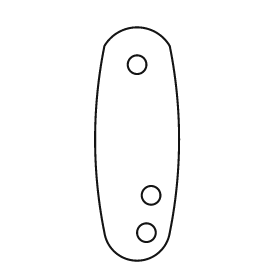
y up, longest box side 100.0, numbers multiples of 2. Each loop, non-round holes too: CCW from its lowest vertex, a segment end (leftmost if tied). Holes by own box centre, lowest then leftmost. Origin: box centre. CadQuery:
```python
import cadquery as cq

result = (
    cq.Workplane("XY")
    .moveTo(-14.0, -38.0)
    .threePointArc((0.0, -50.0), (14.0, -38.0))
    .threePointArc((18.0, 2.0), (14.0, 42.0))
    .threePointArc((0.0, 50.0), (-14.0, 42.0))
    .threePointArc((-18.0, 2.0), (-14.0, -38.0))
    .close()
    .moveTo(4.0, -38.0)
    .circle(4.0)
    .moveTo(6.0, -22.0)
    .circle(4.0)
    .moveTo(0.0, 34.0)
    .circle(4.0)
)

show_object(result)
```